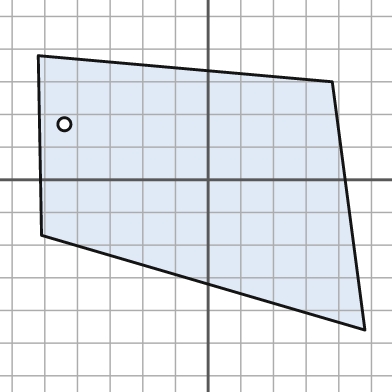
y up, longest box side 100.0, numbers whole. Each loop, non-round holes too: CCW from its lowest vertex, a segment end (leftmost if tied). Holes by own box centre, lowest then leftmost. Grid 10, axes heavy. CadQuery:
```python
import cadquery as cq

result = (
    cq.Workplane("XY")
    .moveTo(48.0, -46.0)
    .lineTo(38.0, 30.0)
    .lineTo(-52.0, 38.0)
    .lineTo(-51.0, -17.0)
    .close()
    .moveTo(-44.0, 17.0)
    .circle(2.0)
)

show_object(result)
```